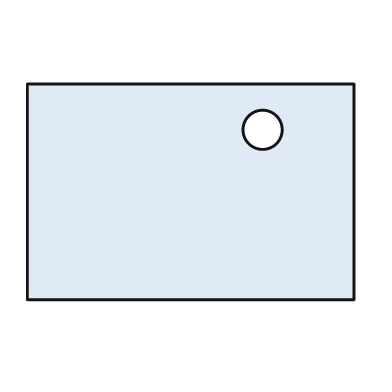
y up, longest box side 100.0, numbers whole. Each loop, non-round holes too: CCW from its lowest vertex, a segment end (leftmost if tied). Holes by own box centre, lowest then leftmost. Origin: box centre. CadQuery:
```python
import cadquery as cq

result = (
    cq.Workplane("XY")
    .moveTo(-50.0, -33.0)
    .lineTo(50.0, -33.0)
    .lineTo(50.0, 33.0)
    .lineTo(-50.0, 33.0)
    .close()
    .moveTo(22.0, 19.0)
    .circle(6.0)
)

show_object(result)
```